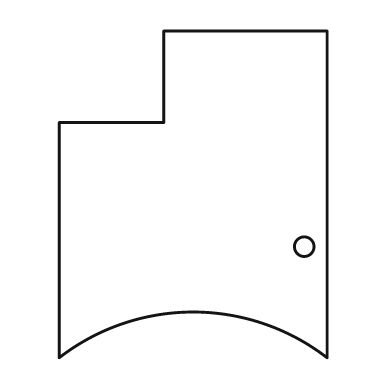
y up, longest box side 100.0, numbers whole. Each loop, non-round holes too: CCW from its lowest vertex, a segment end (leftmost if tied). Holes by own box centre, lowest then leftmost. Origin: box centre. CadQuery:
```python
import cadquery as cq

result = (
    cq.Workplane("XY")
    .moveTo(-41.0, -50.0)
    .threePointArc((0.0, -36.0), (41.0, -50.0))
    .lineTo(41.0, 50.0)
    .lineTo(-9.0, 50.0)
    .lineTo(-9.0, 22.0)
    .lineTo(-41.0, 22.0)
    .close()
    .moveTo(34.0, -16.0)
    .circle(3.0)
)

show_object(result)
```